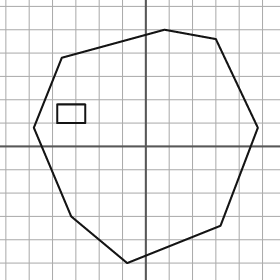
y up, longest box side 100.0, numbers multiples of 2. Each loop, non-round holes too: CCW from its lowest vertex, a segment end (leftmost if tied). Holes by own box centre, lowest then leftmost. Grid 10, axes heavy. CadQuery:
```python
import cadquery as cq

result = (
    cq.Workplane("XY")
    .moveTo(-8.0, -50.0)
    .lineTo(32.0, -34.0)
    .lineTo(48.0, 8.0)
    .lineTo(30.0, 46.0)
    .lineTo(8.0, 50.0)
    .lineTo(-36.0, 38.0)
    .lineTo(-48.0, 8.0)
    .lineTo(-32.0, -30.0)
    .close()
    .moveTo(-38.0, 10.0)
    .lineTo(-26.0, 10.0)
    .lineTo(-26.0, 18.0)
    .lineTo(-38.0, 18.0)
    .close()
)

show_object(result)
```